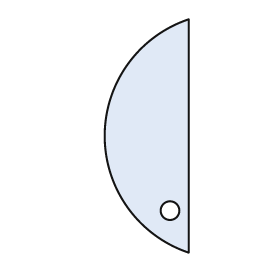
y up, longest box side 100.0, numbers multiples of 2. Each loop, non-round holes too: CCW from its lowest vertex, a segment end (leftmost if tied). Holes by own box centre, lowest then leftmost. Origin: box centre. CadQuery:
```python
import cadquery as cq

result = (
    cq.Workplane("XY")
    .moveTo(18.0, -50.0)
    .lineTo(18.0, 50.0)
    .threePointArc((-18.0, 0.0), (18.0, -50.0))
    .close()
    .moveTo(10.0, -32.0)
    .circle(4.0)
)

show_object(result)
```